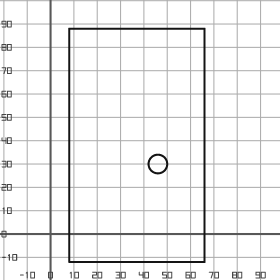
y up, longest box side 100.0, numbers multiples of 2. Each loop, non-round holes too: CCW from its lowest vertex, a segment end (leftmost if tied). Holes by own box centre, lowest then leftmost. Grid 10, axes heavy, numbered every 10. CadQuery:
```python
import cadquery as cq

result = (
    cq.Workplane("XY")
    .moveTo(8.0, -12.0)
    .lineTo(66.0, -12.0)
    .lineTo(66.0, 88.0)
    .lineTo(8.0, 88.0)
    .close()
    .moveTo(46.0, 30.0)
    .circle(4.0)
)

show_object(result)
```